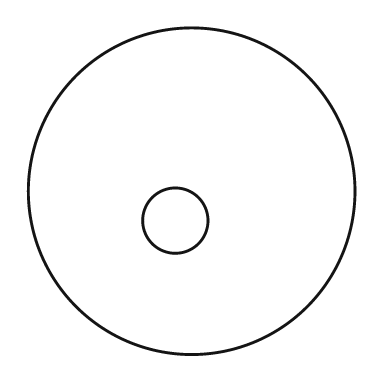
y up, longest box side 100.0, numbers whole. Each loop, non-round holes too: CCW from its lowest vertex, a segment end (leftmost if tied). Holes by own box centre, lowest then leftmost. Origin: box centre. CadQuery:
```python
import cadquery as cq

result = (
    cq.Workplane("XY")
    .moveTo(0.0, 0.0)
    .circle(50.0)
    .moveTo(-5.0, -9.0)
    .circle(10.0)
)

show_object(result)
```